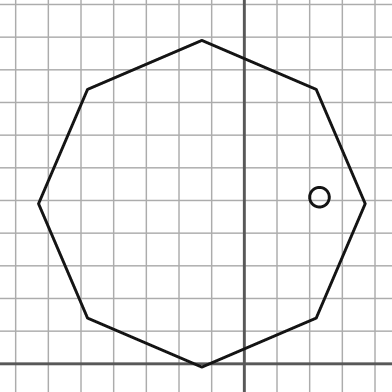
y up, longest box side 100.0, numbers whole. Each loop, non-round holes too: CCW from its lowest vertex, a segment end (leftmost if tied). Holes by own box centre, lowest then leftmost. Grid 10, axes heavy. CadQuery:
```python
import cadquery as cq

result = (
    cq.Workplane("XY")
    .moveTo(-13.0, -1.0)
    .lineTo(22.0, 14.0)
    .lineTo(37.0, 49.0)
    .lineTo(22.0, 84.0)
    .lineTo(-13.0, 99.0)
    .lineTo(-48.0, 84.0)
    .lineTo(-63.0, 49.0)
    .lineTo(-48.0, 14.0)
    .close()
    .moveTo(23.0, 51.0)
    .circle(3.0)
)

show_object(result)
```